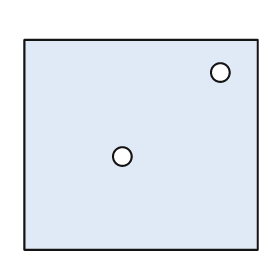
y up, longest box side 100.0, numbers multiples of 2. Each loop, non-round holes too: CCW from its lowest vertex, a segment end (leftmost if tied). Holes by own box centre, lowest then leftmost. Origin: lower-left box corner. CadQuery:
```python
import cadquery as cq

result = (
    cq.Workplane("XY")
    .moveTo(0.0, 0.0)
    .lineTo(100.0, 0.0)
    .lineTo(100.0, 90.0)
    .lineTo(0.0, 90.0)
    .close()
    .moveTo(42.0, 40.0)
    .circle(4.0)
    .moveTo(84.0, 76.0)
    .circle(4.0)
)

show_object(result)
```